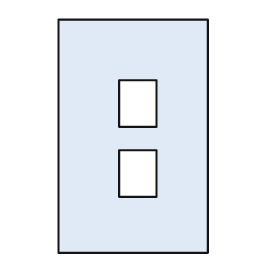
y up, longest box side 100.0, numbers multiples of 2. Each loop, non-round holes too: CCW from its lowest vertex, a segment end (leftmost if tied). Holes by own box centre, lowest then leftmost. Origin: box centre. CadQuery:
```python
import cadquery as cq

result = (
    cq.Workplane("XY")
    .moveTo(-32.0, -50.0)
    .lineTo(32.0, -50.0)
    .lineTo(32.0, 50.0)
    .lineTo(-32.0, 50.0)
    .close()
    .moveTo(-6.0, -26.0)
    .lineTo(10.0, -26.0)
    .lineTo(10.0, -6.0)
    .lineTo(-6.0, -6.0)
    .close()
    .moveTo(-6.0, 4.0)
    .lineTo(10.0, 4.0)
    .lineTo(10.0, 24.0)
    .lineTo(-6.0, 24.0)
    .close()
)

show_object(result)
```